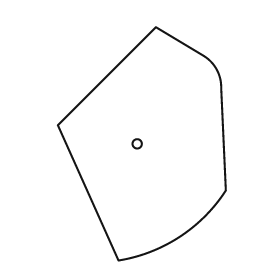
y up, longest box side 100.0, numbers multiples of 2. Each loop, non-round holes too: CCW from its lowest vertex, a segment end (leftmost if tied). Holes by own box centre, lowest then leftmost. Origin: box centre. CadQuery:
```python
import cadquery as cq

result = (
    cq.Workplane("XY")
    .moveTo(-10.0, -50.0)
    .threePointArc((16.0, -40.0), (36.0, -20.0))
    .lineTo(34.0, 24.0)
    .threePointArc((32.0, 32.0), (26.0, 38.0))
    .lineTo(6.0, 50.0)
    .lineTo(-36.0, 8.0)
    .close()
    .moveTo(-2.0, 0.0)
    .circle(2.0)
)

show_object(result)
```